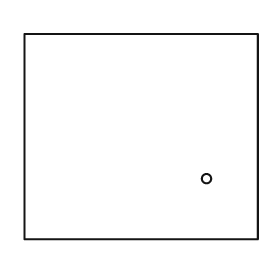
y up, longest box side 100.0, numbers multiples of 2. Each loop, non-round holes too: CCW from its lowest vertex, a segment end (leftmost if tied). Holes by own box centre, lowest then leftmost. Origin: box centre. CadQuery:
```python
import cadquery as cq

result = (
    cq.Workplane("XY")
    .moveTo(-50.0, -44.0)
    .lineTo(50.0, -44.0)
    .lineTo(50.0, 44.0)
    .lineTo(-50.0, 44.0)
    .close()
    .moveTo(28.0, -18.0)
    .circle(2.0)
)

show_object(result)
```